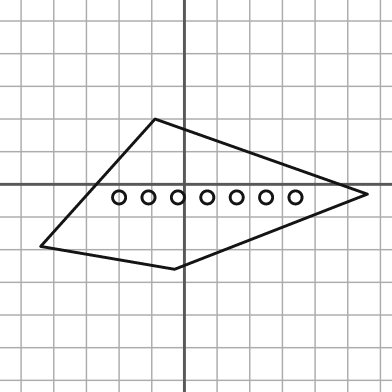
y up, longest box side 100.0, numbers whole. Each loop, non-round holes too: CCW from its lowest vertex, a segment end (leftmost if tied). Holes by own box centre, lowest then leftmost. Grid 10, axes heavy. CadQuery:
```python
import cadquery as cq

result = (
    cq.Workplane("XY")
    .moveTo(-3.0, -26.0)
    .lineTo(56.0, -3.0)
    .lineTo(-9.0, 20.0)
    .lineTo(-44.0, -19.0)
    .close()
    .moveTo(-20.0, -4.0)
    .circle(2.0)
    .moveTo(-11.0, -4.0)
    .circle(2.0)
    .moveTo(-2.0, -4.0)
    .circle(2.0)
    .moveTo(7.0, -4.0)
    .circle(2.0)
    .moveTo(16.0, -4.0)
    .circle(2.0)
    .moveTo(25.0, -4.0)
    .circle(2.0)
    .moveTo(34.0, -4.0)
    .circle(2.0)
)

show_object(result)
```